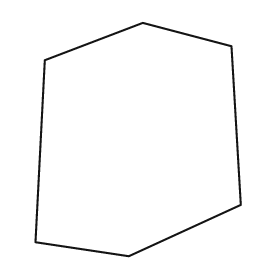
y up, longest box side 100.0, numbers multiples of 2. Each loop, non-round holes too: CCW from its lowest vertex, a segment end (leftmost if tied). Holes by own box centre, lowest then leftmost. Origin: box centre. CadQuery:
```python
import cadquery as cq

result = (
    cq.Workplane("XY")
    .moveTo(-4.0, -50.0)
    .lineTo(44.0, -28.0)
    .lineTo(40.0, 40.0)
    .lineTo(2.0, 50.0)
    .lineTo(-40.0, 34.0)
    .lineTo(-44.0, -44.0)
    .close()
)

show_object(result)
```